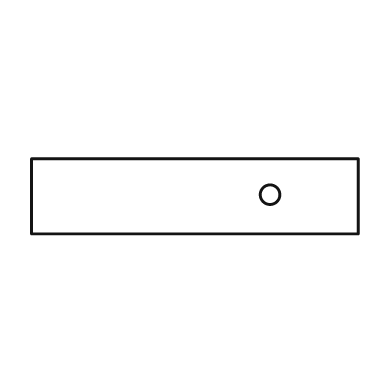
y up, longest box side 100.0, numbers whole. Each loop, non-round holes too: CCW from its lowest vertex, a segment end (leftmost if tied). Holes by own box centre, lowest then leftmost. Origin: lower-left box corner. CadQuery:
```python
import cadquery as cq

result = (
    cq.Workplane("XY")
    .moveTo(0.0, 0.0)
    .lineTo(100.0, 0.0)
    .lineTo(100.0, 23.0)
    .lineTo(0.0, 23.0)
    .close()
    .moveTo(73.0, 12.0)
    .circle(3.0)
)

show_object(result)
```